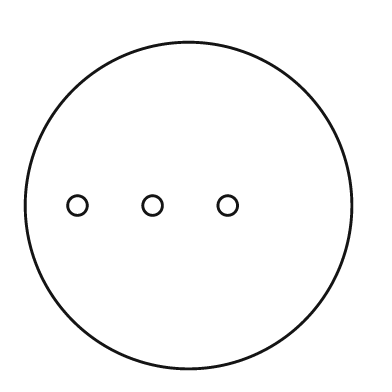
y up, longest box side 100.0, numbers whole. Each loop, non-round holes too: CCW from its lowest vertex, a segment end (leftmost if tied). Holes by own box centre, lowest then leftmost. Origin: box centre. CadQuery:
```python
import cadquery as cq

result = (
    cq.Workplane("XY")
    .moveTo(0.0, 0.0)
    .circle(50.0)
    .moveTo(-34.0, 0.0)
    .circle(3.0)
    .moveTo(-11.0, 0.0)
    .circle(3.0)
    .moveTo(12.0, 0.0)
    .circle(3.0)
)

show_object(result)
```